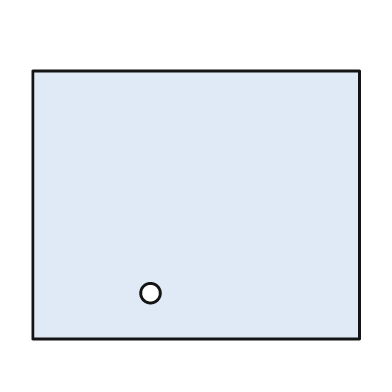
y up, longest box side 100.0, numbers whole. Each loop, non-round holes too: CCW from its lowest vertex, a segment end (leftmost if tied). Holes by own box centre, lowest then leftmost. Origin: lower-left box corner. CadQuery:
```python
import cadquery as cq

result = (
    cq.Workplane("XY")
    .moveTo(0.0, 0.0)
    .lineTo(100.0, 0.0)
    .lineTo(100.0, 82.0)
    .lineTo(0.0, 82.0)
    .close()
    .moveTo(36.0, 14.0)
    .circle(3.0)
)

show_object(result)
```